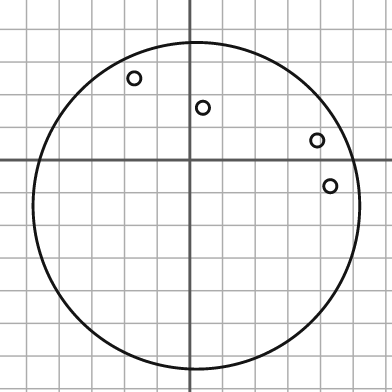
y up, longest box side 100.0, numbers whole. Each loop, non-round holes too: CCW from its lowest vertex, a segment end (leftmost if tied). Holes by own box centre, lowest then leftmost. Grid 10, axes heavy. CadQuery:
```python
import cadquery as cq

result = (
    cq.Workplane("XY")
    .moveTo(2.0, -14.0)
    .circle(50.0)
    .moveTo(43.0, -8.0)
    .circle(2.0)
    .moveTo(39.0, 6.0)
    .circle(2.0)
    .moveTo(4.0, 16.0)
    .circle(2.0)
    .moveTo(-17.0, 25.0)
    .circle(2.0)
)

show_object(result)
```